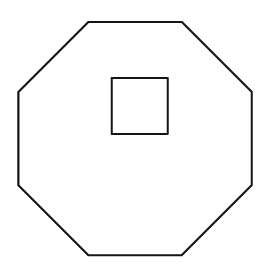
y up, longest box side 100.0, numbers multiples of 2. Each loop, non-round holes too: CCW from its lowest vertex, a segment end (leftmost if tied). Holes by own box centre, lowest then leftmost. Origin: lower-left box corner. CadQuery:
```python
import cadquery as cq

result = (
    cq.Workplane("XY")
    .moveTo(30.0, 0.0)
    .lineTo(70.0, 0.0)
    .lineTo(100.0, 30.0)
    .lineTo(100.0, 70.0)
    .lineTo(70.0, 100.0)
    .lineTo(30.0, 100.0)
    .lineTo(0.0, 70.0)
    .lineTo(0.0, 30.0)
    .close()
    .moveTo(40.0, 52.0)
    .lineTo(64.0, 52.0)
    .lineTo(64.0, 76.0)
    .lineTo(40.0, 76.0)
    .close()
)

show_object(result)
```